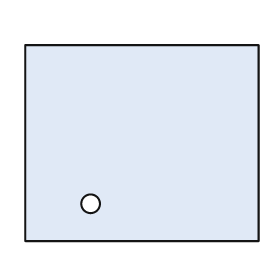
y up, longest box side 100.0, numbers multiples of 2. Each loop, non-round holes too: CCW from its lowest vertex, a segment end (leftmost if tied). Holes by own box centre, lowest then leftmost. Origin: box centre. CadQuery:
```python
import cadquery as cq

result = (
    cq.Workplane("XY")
    .moveTo(-50.0, -42.0)
    .lineTo(50.0, -42.0)
    .lineTo(50.0, 42.0)
    .lineTo(-50.0, 42.0)
    .close()
    .moveTo(-22.0, -26.0)
    .circle(4.0)
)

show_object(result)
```